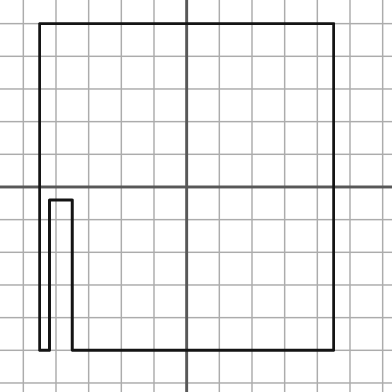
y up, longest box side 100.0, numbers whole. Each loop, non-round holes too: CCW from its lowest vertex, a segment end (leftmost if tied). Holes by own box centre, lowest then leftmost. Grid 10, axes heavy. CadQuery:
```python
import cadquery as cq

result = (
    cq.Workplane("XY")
    .moveTo(-45.0, -50.0)
    .lineTo(-42.0, -50.0)
    .lineTo(-42.0, -4.0)
    .lineTo(-35.0, -4.0)
    .lineTo(-35.0, -50.0)
    .lineTo(45.0, -50.0)
    .lineTo(45.0, 50.0)
    .lineTo(-45.0, 50.0)
    .close()
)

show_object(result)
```